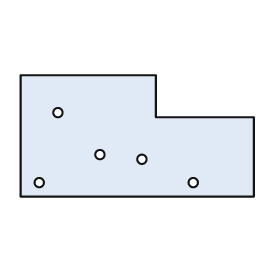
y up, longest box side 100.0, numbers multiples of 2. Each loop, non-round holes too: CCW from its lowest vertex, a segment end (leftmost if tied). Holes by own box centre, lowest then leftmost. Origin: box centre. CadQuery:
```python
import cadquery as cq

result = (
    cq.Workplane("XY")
    .moveTo(-50.0, -26.0)
    .lineTo(50.0, -26.0)
    .lineTo(50.0, 8.0)
    .lineTo(8.0, 8.0)
    .lineTo(8.0, 26.0)
    .lineTo(-50.0, 26.0)
    .close()
    .moveTo(-42.0, -20.0)
    .circle(2.0)
    .moveTo(24.0, -20.0)
    .circle(2.0)
    .moveTo(2.0, -10.0)
    .circle(2.0)
    .moveTo(-16.0, -8.0)
    .circle(2.0)
    .moveTo(-34.0, 10.0)
    .circle(2.0)
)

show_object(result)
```